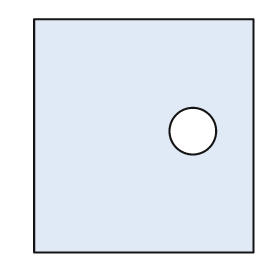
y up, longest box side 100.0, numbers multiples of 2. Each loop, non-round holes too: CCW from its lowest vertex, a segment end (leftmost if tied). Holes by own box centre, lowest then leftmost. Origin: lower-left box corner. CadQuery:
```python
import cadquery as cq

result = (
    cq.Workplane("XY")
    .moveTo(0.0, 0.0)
    .lineTo(94.0, 0.0)
    .lineTo(94.0, 100.0)
    .lineTo(0.0, 100.0)
    .close()
    .moveTo(68.0, 52.0)
    .circle(10.0)
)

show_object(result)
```